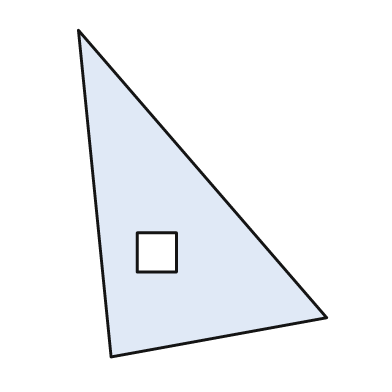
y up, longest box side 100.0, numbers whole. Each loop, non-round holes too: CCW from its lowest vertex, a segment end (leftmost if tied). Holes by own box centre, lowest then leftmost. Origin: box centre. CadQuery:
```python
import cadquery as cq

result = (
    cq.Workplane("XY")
    .moveTo(-28.0, -50.0)
    .lineTo(38.0, -38.0)
    .lineTo(-38.0, 50.0)
    .close()
    .moveTo(-20.0, -24.0)
    .lineTo(-8.0, -24.0)
    .lineTo(-8.0, -12.0)
    .lineTo(-20.0, -12.0)
    .close()
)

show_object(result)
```